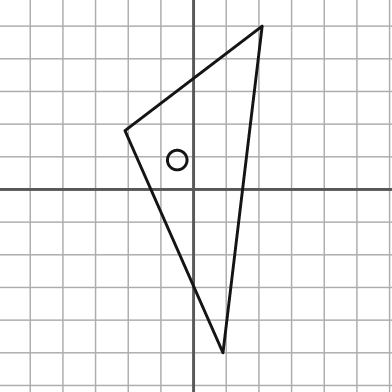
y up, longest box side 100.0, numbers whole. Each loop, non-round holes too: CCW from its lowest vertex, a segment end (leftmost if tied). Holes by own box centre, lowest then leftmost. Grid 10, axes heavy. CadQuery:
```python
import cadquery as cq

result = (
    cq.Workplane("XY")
    .moveTo(9.0, -50.0)
    .lineTo(21.0, 50.0)
    .lineTo(-21.0, 18.0)
    .close()
    .moveTo(-5.0, 9.0)
    .circle(3.0)
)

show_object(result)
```